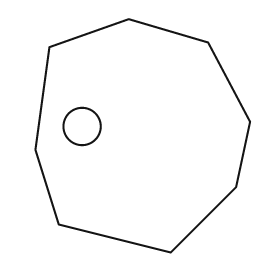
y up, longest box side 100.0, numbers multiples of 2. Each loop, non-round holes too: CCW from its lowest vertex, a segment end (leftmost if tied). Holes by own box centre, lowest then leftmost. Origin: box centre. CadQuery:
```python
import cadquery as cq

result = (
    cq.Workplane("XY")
    .moveTo(12.0, -50.0)
    .lineTo(40.0, -22.0)
    .lineTo(46.0, 6.0)
    .lineTo(28.0, 40.0)
    .lineTo(-6.0, 50.0)
    .lineTo(-40.0, 38.0)
    .lineTo(-46.0, -6.0)
    .lineTo(-36.0, -38.0)
    .close()
    .moveTo(-26.0, 4.0)
    .circle(8.0)
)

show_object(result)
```